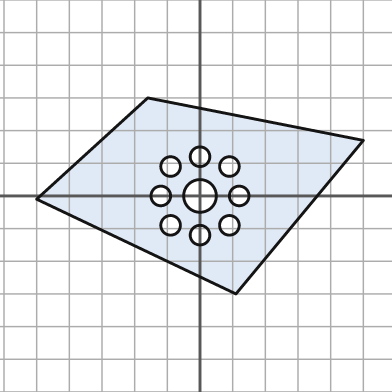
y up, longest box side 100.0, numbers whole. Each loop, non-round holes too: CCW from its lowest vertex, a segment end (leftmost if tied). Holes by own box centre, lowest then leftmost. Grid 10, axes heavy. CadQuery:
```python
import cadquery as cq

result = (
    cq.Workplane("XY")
    .moveTo(11.0, -30.0)
    .lineTo(50.0, 17.0)
    .lineTo(-16.0, 30.0)
    .lineTo(-50.0, -1.0)
    .close()
    .moveTo(0.0, -12.0)
    .circle(3.0)
    .moveTo(-9.0, -9.0)
    .circle(3.0)
    .moveTo(9.0, -9.0)
    .circle(3.0)
    .moveTo(-12.0, 0.0)
    .circle(3.0)
    .moveTo(0.0, 0.0)
    .circle(5.0)
    .moveTo(12.0, 0.0)
    .circle(3.0)
    .moveTo(-9.0, 9.0)
    .circle(3.0)
    .moveTo(9.0, 9.0)
    .circle(3.0)
    .moveTo(0.0, 12.0)
    .circle(3.0)
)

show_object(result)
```